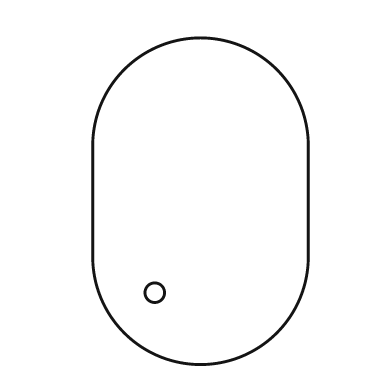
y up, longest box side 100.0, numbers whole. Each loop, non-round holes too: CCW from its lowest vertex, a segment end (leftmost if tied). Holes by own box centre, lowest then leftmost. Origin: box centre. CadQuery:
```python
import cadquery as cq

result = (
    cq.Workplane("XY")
    .moveTo(-33.0, -17.0)
    .threePointArc((0.0, -50.0), (33.0, -17.0))
    .lineTo(33.0, 17.0)
    .threePointArc((0.0, 50.0), (-33.0, 17.0))
    .close()
    .moveTo(-14.0, -28.0)
    .circle(3.0)
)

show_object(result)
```